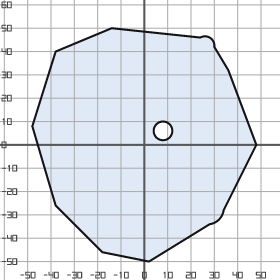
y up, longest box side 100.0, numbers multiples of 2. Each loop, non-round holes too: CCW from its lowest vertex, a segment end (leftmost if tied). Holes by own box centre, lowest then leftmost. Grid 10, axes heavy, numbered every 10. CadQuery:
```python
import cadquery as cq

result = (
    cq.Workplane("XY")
    .moveTo(2.0, -50.0)
    .lineTo(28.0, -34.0)
    .threePointArc((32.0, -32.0), (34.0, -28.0))
    .lineTo(48.0, 0.0)
    .lineTo(36.0, 32.0)
    .lineTo(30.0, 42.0)
    .threePointArc((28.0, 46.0), (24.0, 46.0))
    .lineTo(-14.0, 50.0)
    .lineTo(-38.0, 40.0)
    .lineTo(-48.0, 8.0)
    .lineTo(-38.0, -26.0)
    .lineTo(-18.0, -46.0)
    .close()
    .moveTo(8.0, 6.0)
    .circle(4.0)
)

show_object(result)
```